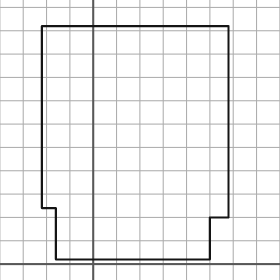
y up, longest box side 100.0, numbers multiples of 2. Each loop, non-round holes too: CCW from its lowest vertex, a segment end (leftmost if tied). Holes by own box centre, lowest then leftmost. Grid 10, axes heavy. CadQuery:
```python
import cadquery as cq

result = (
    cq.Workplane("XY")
    .moveTo(-16.0, 2.0)
    .lineTo(50.0, 2.0)
    .lineTo(50.0, 20.0)
    .lineTo(58.0, 20.0)
    .lineTo(58.0, 102.0)
    .lineTo(-22.0, 102.0)
    .lineTo(-22.0, 24.0)
    .lineTo(-16.0, 24.0)
    .close()
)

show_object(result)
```